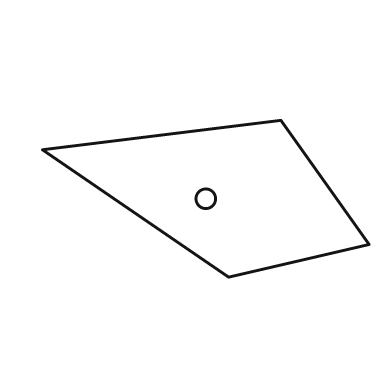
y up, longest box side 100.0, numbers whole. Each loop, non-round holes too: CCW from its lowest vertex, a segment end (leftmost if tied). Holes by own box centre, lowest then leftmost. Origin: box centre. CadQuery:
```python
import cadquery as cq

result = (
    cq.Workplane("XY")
    .moveTo(7.0, -24.0)
    .lineTo(50.0, -14.0)
    .lineTo(23.0, 24.0)
    .lineTo(-50.0, 15.0)
    .close()
    .moveTo(0.0, 0.0)
    .circle(3.0)
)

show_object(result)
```